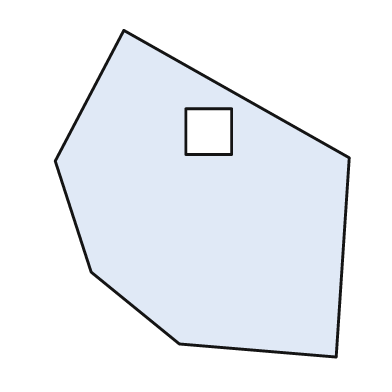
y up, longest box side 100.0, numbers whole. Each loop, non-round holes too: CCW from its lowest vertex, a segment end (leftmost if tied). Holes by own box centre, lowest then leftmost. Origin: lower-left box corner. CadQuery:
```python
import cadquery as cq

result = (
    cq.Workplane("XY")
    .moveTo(86.0, 0.0)
    .lineTo(90.0, 61.0)
    .lineTo(21.0, 100.0)
    .lineTo(0.0, 60.0)
    .lineTo(11.0, 26.0)
    .lineTo(38.0, 4.0)
    .close()
    .moveTo(40.0, 62.0)
    .lineTo(54.0, 62.0)
    .lineTo(54.0, 76.0)
    .lineTo(40.0, 76.0)
    .close()
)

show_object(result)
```